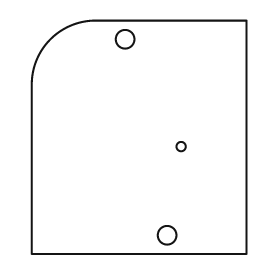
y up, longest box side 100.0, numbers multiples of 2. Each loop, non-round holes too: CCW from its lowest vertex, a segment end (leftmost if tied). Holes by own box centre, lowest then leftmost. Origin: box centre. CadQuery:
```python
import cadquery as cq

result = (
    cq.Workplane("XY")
    .moveTo(-46.0, -50.0)
    .lineTo(46.0, -50.0)
    .lineTo(46.0, 50.0)
    .lineTo(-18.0, 50.0)
    .threePointArc((-38.0, 42.0), (-46.0, 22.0))
    .close()
    .moveTo(12.0, -42.0)
    .circle(4.0)
    .moveTo(18.0, -4.0)
    .circle(2.0)
    .moveTo(-6.0, 42.0)
    .circle(4.0)
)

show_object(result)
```